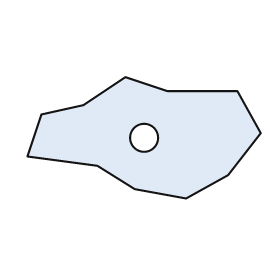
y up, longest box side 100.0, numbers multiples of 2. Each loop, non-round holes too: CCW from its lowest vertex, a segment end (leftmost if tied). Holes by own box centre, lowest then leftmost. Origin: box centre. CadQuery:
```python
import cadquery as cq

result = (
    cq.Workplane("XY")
    .moveTo(18.0, -26.0)
    .lineTo(36.0, -16.0)
    .lineTo(50.0, 2.0)
    .lineTo(40.0, 20.0)
    .lineTo(10.0, 20.0)
    .lineTo(-8.0, 26.0)
    .lineTo(-26.0, 14.0)
    .lineTo(-44.0, 10.0)
    .lineTo(-50.0, -8.0)
    .lineTo(-20.0, -12.0)
    .lineTo(-4.0, -22.0)
    .close()
    .moveTo(0.0, 0.0)
    .circle(6.0)
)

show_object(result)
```